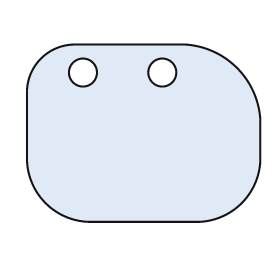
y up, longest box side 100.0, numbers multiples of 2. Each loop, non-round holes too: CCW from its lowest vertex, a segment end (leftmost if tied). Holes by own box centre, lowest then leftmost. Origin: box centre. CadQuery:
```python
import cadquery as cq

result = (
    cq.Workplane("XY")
    .moveTo(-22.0, -38.0)
    .lineTo(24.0, -38.0)
    .threePointArc((42.0, -30.0), (50.0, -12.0))
    .lineTo(50.0, 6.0)
    .threePointArc((40.0, 28.0), (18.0, 38.0))
    .lineTo(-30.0, 38.0)
    .threePointArc((-44.0, 32.0), (-50.0, 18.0))
    .lineTo(-50.0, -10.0)
    .threePointArc((-42.0, -30.0), (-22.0, -38.0))
    .close()
    .moveTo(-26.0, 26.0)
    .circle(6.0)
    .moveTo(8.0, 26.0)
    .circle(6.0)
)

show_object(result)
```